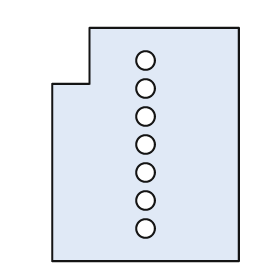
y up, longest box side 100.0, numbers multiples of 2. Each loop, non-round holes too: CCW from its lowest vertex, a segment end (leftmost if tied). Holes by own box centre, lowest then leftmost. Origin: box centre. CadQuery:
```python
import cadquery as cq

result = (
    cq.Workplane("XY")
    .moveTo(-40.0, -50.0)
    .lineTo(40.0, -50.0)
    .lineTo(40.0, 50.0)
    .lineTo(-24.0, 50.0)
    .lineTo(-24.0, 26.0)
    .lineTo(-40.0, 26.0)
    .close()
    .moveTo(0.0, -36.0)
    .circle(4.0)
    .moveTo(0.0, -24.0)
    .circle(4.0)
    .moveTo(0.0, -12.0)
    .circle(4.0)
    .moveTo(0.0, 0.0)
    .circle(4.0)
    .moveTo(0.0, 12.0)
    .circle(4.0)
    .moveTo(0.0, 24.0)
    .circle(4.0)
    .moveTo(0.0, 36.0)
    .circle(4.0)
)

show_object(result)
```